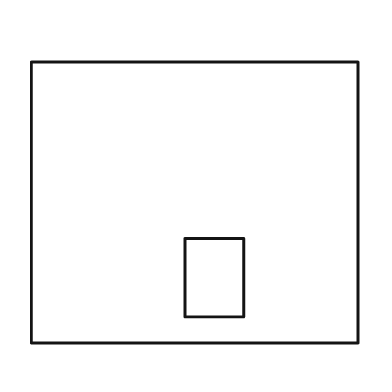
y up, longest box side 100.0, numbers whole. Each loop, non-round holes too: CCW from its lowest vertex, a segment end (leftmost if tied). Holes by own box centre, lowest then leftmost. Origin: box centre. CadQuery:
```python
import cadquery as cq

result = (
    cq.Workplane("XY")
    .moveTo(-50.0, -43.0)
    .lineTo(50.0, -43.0)
    .lineTo(50.0, 43.0)
    .lineTo(-50.0, 43.0)
    .close()
    .moveTo(-3.0, -35.0)
    .lineTo(15.0, -35.0)
    .lineTo(15.0, -11.0)
    .lineTo(-3.0, -11.0)
    .close()
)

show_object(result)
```